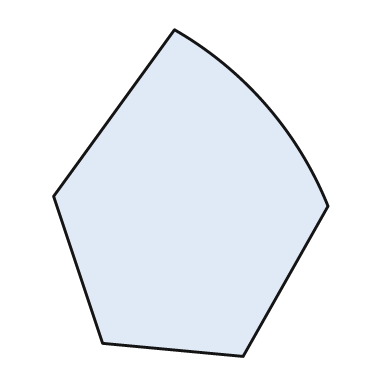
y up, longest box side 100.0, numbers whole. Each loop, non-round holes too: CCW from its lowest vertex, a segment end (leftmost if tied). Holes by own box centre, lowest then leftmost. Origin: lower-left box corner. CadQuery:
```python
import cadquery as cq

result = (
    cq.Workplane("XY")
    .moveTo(58.0, 0.0)
    .lineTo(84.0, 46.0)
    .threePointArc((65.0, 77.0), (37.0, 100.0))
    .lineTo(0.0, 49.0)
    .lineTo(15.0, 4.0)
    .close()
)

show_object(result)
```